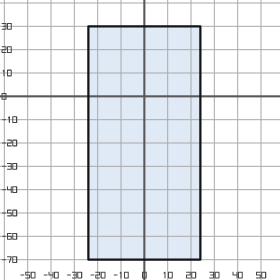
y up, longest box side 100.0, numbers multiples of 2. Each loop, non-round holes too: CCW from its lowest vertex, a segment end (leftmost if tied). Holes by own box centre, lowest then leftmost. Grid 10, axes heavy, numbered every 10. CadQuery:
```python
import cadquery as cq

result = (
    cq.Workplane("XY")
    .moveTo(-24.0, -70.0)
    .lineTo(24.0, -70.0)
    .lineTo(24.0, 30.0)
    .lineTo(-24.0, 30.0)
    .close()
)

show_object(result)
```